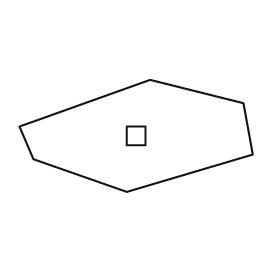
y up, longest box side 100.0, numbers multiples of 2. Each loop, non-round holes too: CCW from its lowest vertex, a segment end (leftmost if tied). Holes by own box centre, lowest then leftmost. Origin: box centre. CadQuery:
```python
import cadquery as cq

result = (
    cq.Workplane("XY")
    .moveTo(-4.0, -24.0)
    .lineTo(50.0, -8.0)
    .lineTo(46.0, 14.0)
    .lineTo(6.0, 24.0)
    .lineTo(-50.0, 4.0)
    .lineTo(-44.0, -10.0)
    .close()
    .moveTo(-4.0, -4.0)
    .lineTo(4.0, -4.0)
    .lineTo(4.0, 4.0)
    .lineTo(-4.0, 4.0)
    .close()
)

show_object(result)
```